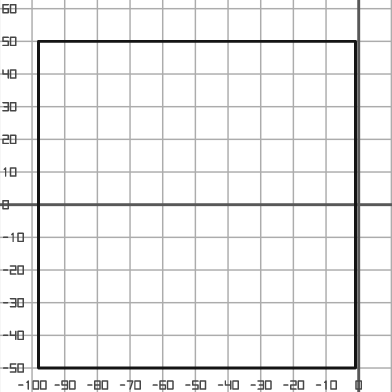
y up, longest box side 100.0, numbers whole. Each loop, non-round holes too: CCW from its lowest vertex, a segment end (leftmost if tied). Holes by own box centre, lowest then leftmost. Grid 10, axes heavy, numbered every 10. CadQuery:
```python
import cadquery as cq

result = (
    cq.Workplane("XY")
    .moveTo(-98.0, -50.0)
    .lineTo(-1.0, -50.0)
    .lineTo(-1.0, 50.0)
    .lineTo(-98.0, 50.0)
    .close()
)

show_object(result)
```